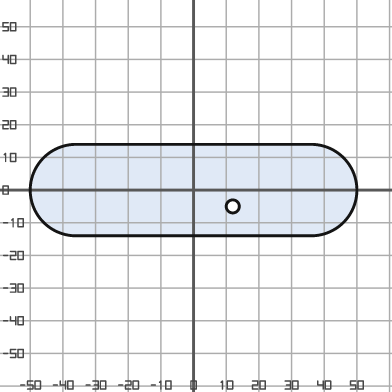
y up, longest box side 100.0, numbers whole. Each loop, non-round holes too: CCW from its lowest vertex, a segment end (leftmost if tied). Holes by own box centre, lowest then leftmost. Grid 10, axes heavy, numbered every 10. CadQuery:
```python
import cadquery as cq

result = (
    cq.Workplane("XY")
    .moveTo(-36.0, -14.0)
    .lineTo(36.0, -14.0)
    .threePointArc((50.0, 0.0), (36.0, 14.0))
    .lineTo(-36.0, 14.0)
    .threePointArc((-50.0, 0.0), (-36.0, -14.0))
    .close()
    .moveTo(12.0, -5.0)
    .circle(2.0)
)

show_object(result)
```